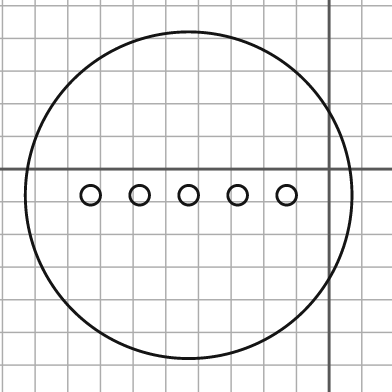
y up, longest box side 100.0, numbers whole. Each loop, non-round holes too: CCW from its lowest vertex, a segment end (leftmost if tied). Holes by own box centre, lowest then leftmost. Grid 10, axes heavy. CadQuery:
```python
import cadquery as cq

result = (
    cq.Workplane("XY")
    .moveTo(-43.0, -8.0)
    .circle(50.0)
    .moveTo(-73.0, -8.0)
    .circle(3.0)
    .moveTo(-58.0, -8.0)
    .circle(3.0)
    .moveTo(-43.0, -8.0)
    .circle(3.0)
    .moveTo(-28.0, -8.0)
    .circle(3.0)
    .moveTo(-13.0, -8.0)
    .circle(3.0)
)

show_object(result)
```